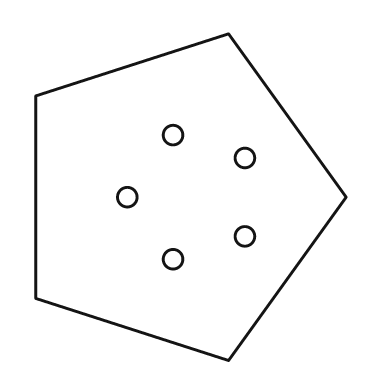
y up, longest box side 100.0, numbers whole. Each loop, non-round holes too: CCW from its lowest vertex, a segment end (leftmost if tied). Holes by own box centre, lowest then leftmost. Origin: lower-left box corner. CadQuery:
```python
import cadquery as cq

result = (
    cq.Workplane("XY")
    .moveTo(59.0, 0.0)
    .lineTo(95.0, 50.0)
    .lineTo(59.0, 100.0)
    .lineTo(0.0, 81.0)
    .lineTo(0.0, 19.0)
    .close()
    .moveTo(42.0, 31.0)
    .circle(3.0)
    .moveTo(64.0, 38.0)
    .circle(3.0)
    .moveTo(28.0, 50.0)
    .circle(3.0)
    .moveTo(64.0, 62.0)
    .circle(3.0)
    .moveTo(42.0, 69.0)
    .circle(3.0)
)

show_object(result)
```